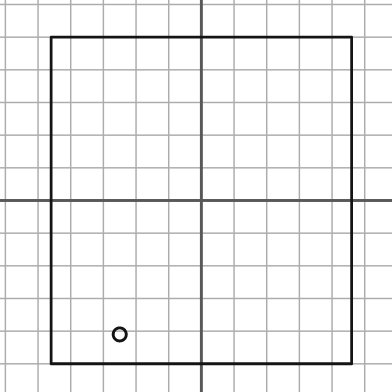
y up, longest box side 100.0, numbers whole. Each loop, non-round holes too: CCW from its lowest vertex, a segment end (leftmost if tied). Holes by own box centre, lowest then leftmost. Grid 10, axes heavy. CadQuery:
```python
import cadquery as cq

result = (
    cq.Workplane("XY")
    .moveTo(-46.0, -50.0)
    .lineTo(46.0, -50.0)
    .lineTo(46.0, 50.0)
    .lineTo(-46.0, 50.0)
    .close()
    .moveTo(-25.0, -41.0)
    .circle(2.0)
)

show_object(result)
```